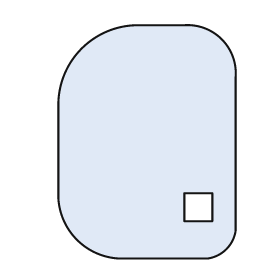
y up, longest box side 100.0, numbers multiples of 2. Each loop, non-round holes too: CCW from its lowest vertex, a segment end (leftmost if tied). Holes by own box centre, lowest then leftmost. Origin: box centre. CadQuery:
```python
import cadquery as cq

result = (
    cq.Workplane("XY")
    .moveTo(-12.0, -50.0)
    .lineTo(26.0, -50.0)
    .threePointArc((34.0, -46.0), (38.0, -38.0))
    .lineTo(38.0, 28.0)
    .threePointArc((32.0, 44.0), (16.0, 50.0))
    .lineTo(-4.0, 50.0)
    .threePointArc((-28.0, 40.0), (-38.0, 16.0))
    .lineTo(-38.0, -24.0)
    .threePointArc((-30.0, -42.0), (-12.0, -50.0))
    .close()
    .moveTo(16.0, -34.0)
    .lineTo(28.0, -34.0)
    .lineTo(28.0, -22.0)
    .lineTo(16.0, -22.0)
    .close()
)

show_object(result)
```